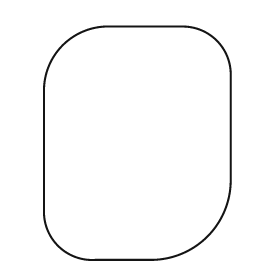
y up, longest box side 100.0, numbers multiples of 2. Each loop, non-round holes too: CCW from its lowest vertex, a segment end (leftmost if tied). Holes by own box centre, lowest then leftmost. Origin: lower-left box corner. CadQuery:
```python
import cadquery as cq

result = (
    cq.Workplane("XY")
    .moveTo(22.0, 0.0)
    .lineTo(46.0, 0.0)
    .threePointArc((70.0, 10.0), (80.0, 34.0))
    .lineTo(80.0, 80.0)
    .threePointArc((74.0, 94.0), (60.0, 100.0))
    .lineTo(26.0, 100.0)
    .threePointArc((8.0, 92.0), (0.0, 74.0))
    .lineTo(0.0, 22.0)
    .threePointArc((6.0, 6.0), (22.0, 0.0))
    .close()
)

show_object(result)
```